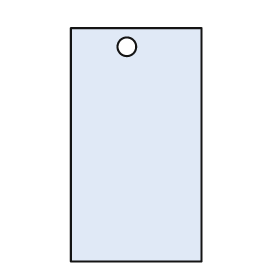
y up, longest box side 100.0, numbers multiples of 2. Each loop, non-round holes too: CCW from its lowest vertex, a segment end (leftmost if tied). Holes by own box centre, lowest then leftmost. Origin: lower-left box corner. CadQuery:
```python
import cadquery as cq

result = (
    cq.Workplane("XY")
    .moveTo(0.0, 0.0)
    .lineTo(56.0, 0.0)
    .lineTo(56.0, 100.0)
    .lineTo(0.0, 100.0)
    .close()
    .moveTo(24.0, 92.0)
    .circle(4.0)
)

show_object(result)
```